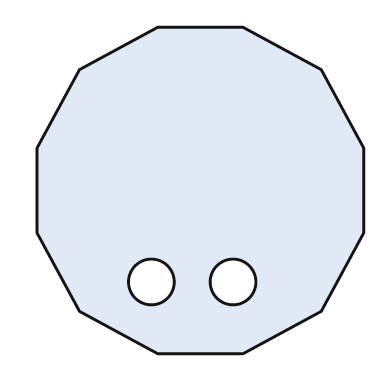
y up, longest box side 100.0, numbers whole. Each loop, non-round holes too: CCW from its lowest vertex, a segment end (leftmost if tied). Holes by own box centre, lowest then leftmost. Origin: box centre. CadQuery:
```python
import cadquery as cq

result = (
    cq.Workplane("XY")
    .moveTo(-13.0, -50.0)
    .lineTo(13.0, -50.0)
    .lineTo(37.0, -37.0)
    .lineTo(50.0, -13.0)
    .lineTo(50.0, 13.0)
    .lineTo(37.0, 37.0)
    .lineTo(13.0, 50.0)
    .lineTo(-13.0, 50.0)
    .lineTo(-37.0, 37.0)
    .lineTo(-50.0, 13.0)
    .lineTo(-50.0, -13.0)
    .lineTo(-37.0, -37.0)
    .close()
    .moveTo(-15.0, -28.0)
    .circle(7.0)
    .moveTo(10.0, -28.0)
    .circle(7.0)
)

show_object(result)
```